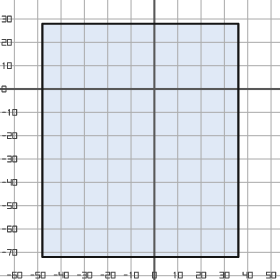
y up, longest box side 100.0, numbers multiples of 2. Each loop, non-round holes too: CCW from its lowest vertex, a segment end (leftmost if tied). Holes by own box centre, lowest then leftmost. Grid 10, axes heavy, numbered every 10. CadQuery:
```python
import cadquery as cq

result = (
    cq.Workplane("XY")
    .moveTo(-48.0, -72.0)
    .lineTo(36.0, -72.0)
    .lineTo(36.0, 28.0)
    .lineTo(-48.0, 28.0)
    .close()
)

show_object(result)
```